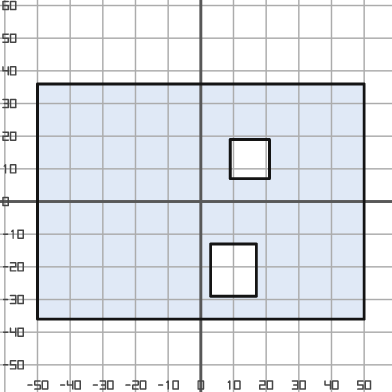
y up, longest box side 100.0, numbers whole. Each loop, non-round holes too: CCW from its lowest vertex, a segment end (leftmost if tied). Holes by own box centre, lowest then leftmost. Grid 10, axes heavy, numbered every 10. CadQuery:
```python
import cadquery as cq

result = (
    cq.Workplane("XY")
    .moveTo(-50.0, -36.0)
    .lineTo(50.0, -36.0)
    .lineTo(50.0, 36.0)
    .lineTo(-50.0, 36.0)
    .close()
    .moveTo(3.0, -29.0)
    .lineTo(17.0, -29.0)
    .lineTo(17.0, -13.0)
    .lineTo(3.0, -13.0)
    .close()
    .moveTo(9.0, 7.0)
    .lineTo(21.0, 7.0)
    .lineTo(21.0, 19.0)
    .lineTo(9.0, 19.0)
    .close()
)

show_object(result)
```